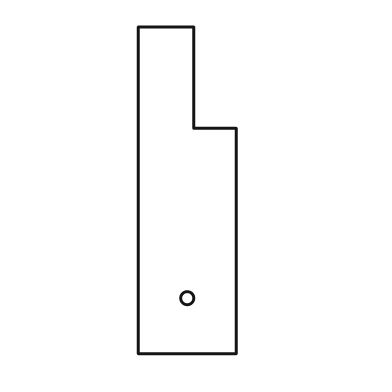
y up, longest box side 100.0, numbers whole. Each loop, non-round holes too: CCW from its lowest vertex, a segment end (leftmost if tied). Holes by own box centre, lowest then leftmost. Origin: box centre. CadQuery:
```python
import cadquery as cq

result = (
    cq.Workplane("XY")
    .moveTo(-15.0, -50.0)
    .lineTo(15.0, -50.0)
    .lineTo(15.0, 19.0)
    .lineTo(2.0, 19.0)
    .lineTo(2.0, 50.0)
    .lineTo(-15.0, 50.0)
    .close()
    .moveTo(0.0, -33.0)
    .circle(2.0)
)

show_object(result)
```